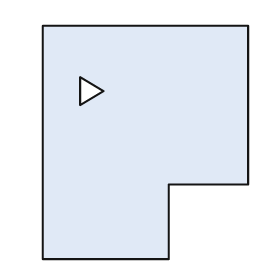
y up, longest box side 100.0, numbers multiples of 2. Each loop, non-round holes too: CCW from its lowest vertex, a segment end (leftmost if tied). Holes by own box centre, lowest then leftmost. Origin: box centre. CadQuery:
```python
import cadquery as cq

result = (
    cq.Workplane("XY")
    .moveTo(-44.0, -50.0)
    .lineTo(10.0, -50.0)
    .lineTo(10.0, -18.0)
    .lineTo(44.0, -18.0)
    .lineTo(44.0, 50.0)
    .lineTo(-44.0, 50.0)
    .close()
    .moveTo(-28.0, 16.0)
    .lineTo(-18.0, 22.0)
    .lineTo(-28.0, 28.0)
    .close()
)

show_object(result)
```